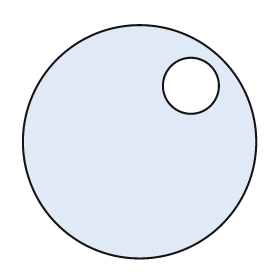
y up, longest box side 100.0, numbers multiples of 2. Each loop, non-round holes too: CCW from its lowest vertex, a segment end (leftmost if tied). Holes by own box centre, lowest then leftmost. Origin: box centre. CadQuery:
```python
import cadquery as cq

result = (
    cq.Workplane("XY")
    .moveTo(0.0, 0.0)
    .circle(50.0)
    .moveTo(22.0, 24.0)
    .circle(12.0)
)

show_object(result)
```